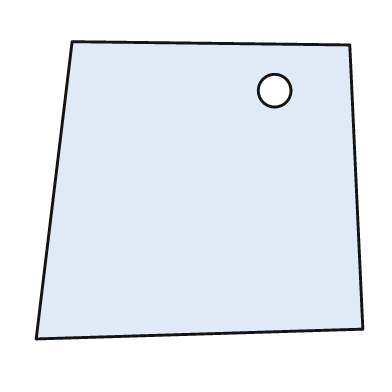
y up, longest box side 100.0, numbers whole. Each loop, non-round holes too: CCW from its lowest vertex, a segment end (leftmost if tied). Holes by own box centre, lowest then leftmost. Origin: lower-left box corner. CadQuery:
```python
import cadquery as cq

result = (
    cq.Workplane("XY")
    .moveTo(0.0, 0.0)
    .lineTo(100.0, 3.0)
    .lineTo(96.0, 90.0)
    .lineTo(11.0, 91.0)
    .close()
    .moveTo(73.0, 76.0)
    .circle(5.0)
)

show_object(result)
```